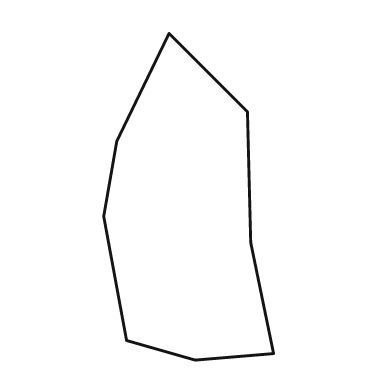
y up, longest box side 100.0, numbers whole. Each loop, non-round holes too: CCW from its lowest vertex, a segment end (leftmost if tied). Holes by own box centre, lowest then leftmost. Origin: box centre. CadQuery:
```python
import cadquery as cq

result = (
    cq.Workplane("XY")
    .moveTo(2.0, -50.0)
    .lineTo(26.0, -48.0)
    .lineTo(19.0, -14.0)
    .lineTo(18.0, 26.0)
    .lineTo(-6.0, 50.0)
    .lineTo(-22.0, 17.0)
    .lineTo(-26.0, -6.0)
    .lineTo(-19.0, -44.0)
    .close()
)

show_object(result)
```